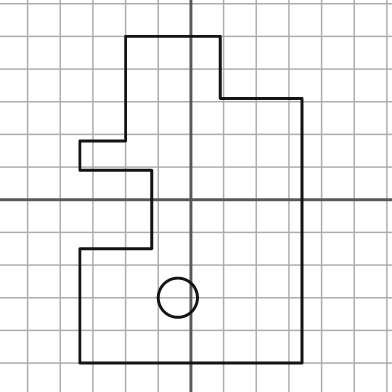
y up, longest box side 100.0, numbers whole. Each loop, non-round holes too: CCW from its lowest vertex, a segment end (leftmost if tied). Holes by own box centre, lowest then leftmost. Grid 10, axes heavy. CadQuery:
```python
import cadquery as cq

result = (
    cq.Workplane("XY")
    .moveTo(-34.0, -50.0)
    .lineTo(34.0, -50.0)
    .lineTo(34.0, 31.0)
    .lineTo(9.0, 31.0)
    .lineTo(9.0, 50.0)
    .lineTo(-20.0, 50.0)
    .lineTo(-20.0, 18.0)
    .lineTo(-34.0, 18.0)
    .lineTo(-34.0, 9.0)
    .lineTo(-12.0, 9.0)
    .lineTo(-12.0, -15.0)
    .lineTo(-34.0, -15.0)
    .close()
    .moveTo(-4.0, -30.0)
    .circle(6.0)
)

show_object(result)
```